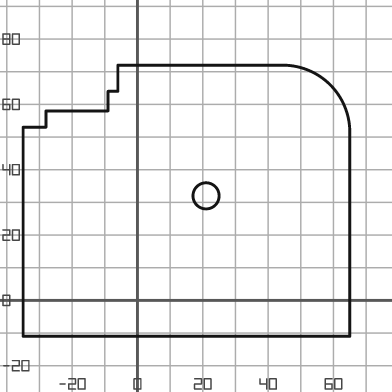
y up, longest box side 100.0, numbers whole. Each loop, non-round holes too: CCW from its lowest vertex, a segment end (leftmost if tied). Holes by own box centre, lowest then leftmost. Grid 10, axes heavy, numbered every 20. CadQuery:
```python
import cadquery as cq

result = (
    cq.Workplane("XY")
    .moveTo(-35.0, -11.0)
    .lineTo(65.0, -11.0)
    .lineTo(65.0, 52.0)
    .threePointArc((59.0, 66.0), (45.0, 72.0))
    .lineTo(-6.0, 72.0)
    .lineTo(-6.0, 64.0)
    .lineTo(-9.0, 64.0)
    .lineTo(-9.0, 58.0)
    .lineTo(-28.0, 58.0)
    .lineTo(-28.0, 53.0)
    .lineTo(-35.0, 53.0)
    .close()
    .moveTo(21.0, 32.0)
    .circle(4.0)
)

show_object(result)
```